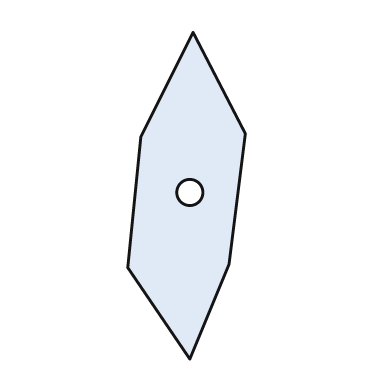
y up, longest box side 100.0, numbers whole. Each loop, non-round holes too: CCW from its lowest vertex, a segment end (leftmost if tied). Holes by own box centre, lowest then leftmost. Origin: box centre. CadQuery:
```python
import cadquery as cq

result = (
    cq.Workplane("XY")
    .moveTo(1.0, -50.0)
    .lineTo(13.0, -21.0)
    .lineTo(18.0, 19.0)
    .lineTo(2.0, 50.0)
    .lineTo(-14.0, 18.0)
    .lineTo(-18.0, -22.0)
    .close()
    .moveTo(1.0, 1.0)
    .circle(4.0)
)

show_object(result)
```